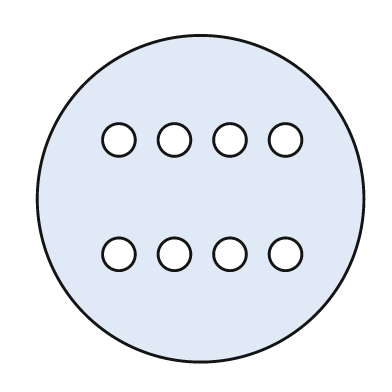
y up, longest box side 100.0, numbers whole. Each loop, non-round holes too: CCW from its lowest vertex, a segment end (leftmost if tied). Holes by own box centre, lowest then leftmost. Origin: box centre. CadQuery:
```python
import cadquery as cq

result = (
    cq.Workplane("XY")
    .moveTo(0.0, 0.0)
    .circle(50.0)
    .moveTo(-25.0, -17.0)
    .circle(5.0)
    .moveTo(-8.0, -17.0)
    .circle(5.0)
    .moveTo(9.0, -17.0)
    .circle(5.0)
    .moveTo(26.0, -17.0)
    .circle(5.0)
    .moveTo(-25.0, 18.0)
    .circle(5.0)
    .moveTo(-8.0, 18.0)
    .circle(5.0)
    .moveTo(9.0, 18.0)
    .circle(5.0)
    .moveTo(26.0, 18.0)
    .circle(5.0)
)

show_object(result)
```